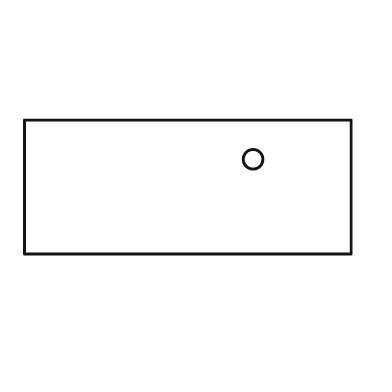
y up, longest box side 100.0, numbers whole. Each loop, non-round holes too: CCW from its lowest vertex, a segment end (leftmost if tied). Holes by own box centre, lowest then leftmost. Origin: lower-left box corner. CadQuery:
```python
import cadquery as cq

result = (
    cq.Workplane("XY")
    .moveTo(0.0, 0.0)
    .lineTo(100.0, 0.0)
    .lineTo(100.0, 41.0)
    .lineTo(0.0, 41.0)
    .close()
    .moveTo(70.0, 29.0)
    .circle(3.0)
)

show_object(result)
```